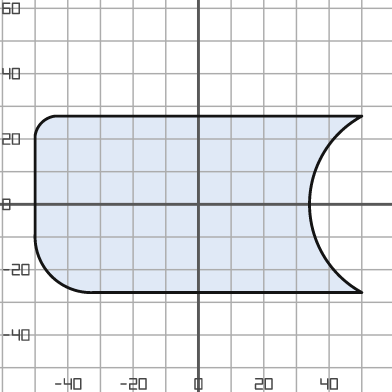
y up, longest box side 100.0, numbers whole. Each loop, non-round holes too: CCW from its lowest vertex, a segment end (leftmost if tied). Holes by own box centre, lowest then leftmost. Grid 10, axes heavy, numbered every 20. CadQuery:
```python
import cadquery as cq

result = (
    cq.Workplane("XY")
    .moveTo(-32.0, -27.0)
    .lineTo(50.0, -27.0)
    .threePointArc((34.0, 0.0), (50.0, 27.0))
    .lineTo(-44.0, 27.0)
    .threePointArc((-48.0, 25.0), (-50.0, 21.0))
    .lineTo(-50.0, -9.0)
    .threePointArc((-45.0, -22.0), (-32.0, -27.0))
    .close()
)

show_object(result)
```